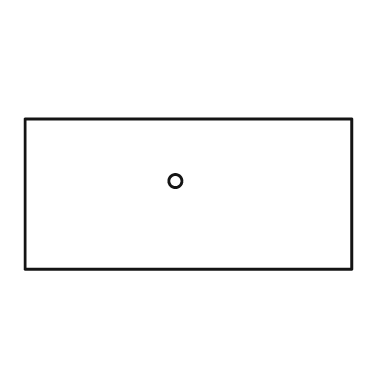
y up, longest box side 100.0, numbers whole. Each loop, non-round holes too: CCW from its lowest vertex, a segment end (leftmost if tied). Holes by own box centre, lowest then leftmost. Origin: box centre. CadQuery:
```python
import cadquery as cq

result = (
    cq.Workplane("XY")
    .moveTo(-50.0, -23.0)
    .lineTo(50.0, -23.0)
    .lineTo(50.0, 23.0)
    .lineTo(-50.0, 23.0)
    .close()
    .moveTo(-4.0, 4.0)
    .circle(2.0)
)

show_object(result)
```